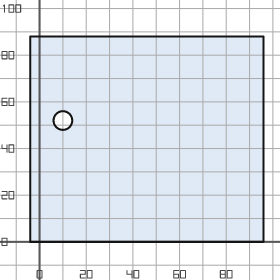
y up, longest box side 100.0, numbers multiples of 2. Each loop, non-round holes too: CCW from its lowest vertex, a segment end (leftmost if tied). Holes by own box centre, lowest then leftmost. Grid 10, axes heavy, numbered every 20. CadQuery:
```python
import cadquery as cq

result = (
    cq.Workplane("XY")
    .moveTo(-4.0, 0.0)
    .lineTo(96.0, 0.0)
    .lineTo(96.0, 88.0)
    .lineTo(-4.0, 88.0)
    .close()
    .moveTo(10.0, 52.0)
    .circle(4.0)
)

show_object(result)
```